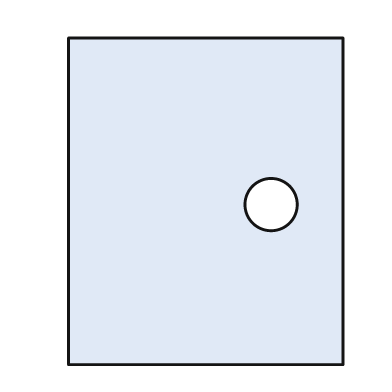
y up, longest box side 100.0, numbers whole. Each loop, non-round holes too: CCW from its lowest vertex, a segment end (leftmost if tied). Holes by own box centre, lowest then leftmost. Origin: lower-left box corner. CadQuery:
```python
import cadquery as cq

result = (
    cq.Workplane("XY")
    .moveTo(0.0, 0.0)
    .lineTo(84.0, 0.0)
    .lineTo(84.0, 100.0)
    .lineTo(0.0, 100.0)
    .close()
    .moveTo(62.0, 49.0)
    .circle(8.0)
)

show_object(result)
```